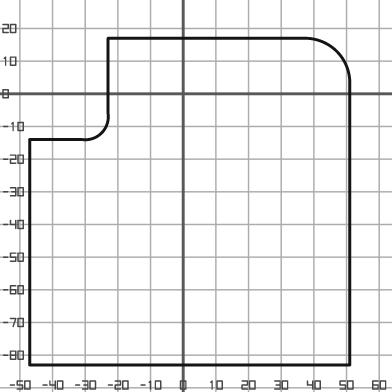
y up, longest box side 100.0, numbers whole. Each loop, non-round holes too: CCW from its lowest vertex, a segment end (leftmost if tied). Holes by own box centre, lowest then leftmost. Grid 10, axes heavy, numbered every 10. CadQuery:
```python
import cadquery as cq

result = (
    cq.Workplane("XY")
    .moveTo(-47.0, -83.0)
    .lineTo(51.0, -83.0)
    .lineTo(51.0, 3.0)
    .threePointArc((47.0, 13.0), (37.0, 17.0))
    .lineTo(-23.0, 17.0)
    .lineTo(-23.0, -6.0)
    .threePointArc((-25.0, -12.0), (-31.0, -14.0))
    .lineTo(-47.0, -14.0)
    .close()
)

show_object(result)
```